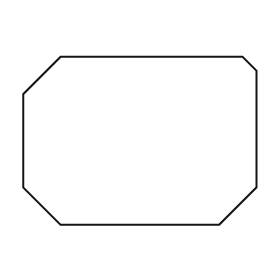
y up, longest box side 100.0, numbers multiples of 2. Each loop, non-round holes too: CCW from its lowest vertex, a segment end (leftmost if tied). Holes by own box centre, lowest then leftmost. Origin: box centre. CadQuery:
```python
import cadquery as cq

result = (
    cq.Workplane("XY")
    .moveTo(-34.0, -36.0)
    .lineTo(34.0, -36.0)
    .lineTo(50.0, -20.0)
    .lineTo(50.0, 30.0)
    .lineTo(44.0, 36.0)
    .lineTo(-34.0, 36.0)
    .lineTo(-50.0, 20.0)
    .lineTo(-50.0, -20.0)
    .close()
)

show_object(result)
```